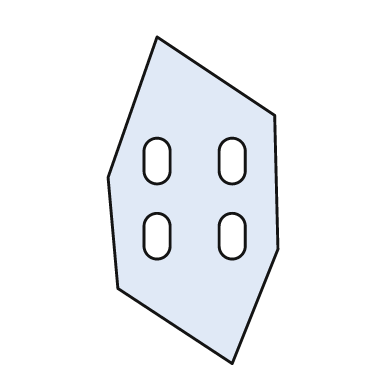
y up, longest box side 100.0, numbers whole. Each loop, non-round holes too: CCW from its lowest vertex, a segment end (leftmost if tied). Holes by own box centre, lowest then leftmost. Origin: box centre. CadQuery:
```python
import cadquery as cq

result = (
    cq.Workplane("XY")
    .moveTo(12.0, -50.0)
    .lineTo(26.0, -15.0)
    .lineTo(25.0, 26.0)
    .lineTo(-11.0, 50.0)
    .lineTo(-26.0, 7.0)
    .lineTo(-23.0, -27.0)
    .close()
    .moveTo(-15.0, -14.0)
    .threePointArc((-11.0, -18.0), (-7.0, -14.0))
    .lineTo(-7.0, -8.0)
    .threePointArc((-11.0, -4.0), (-15.0, -8.0))
    .close()
    .moveTo(8.0, -14.0)
    .threePointArc((12.0, -18.0), (16.0, -14.0))
    .lineTo(16.0, -8.0)
    .threePointArc((12.0, -4.0), (8.0, -8.0))
    .close()
    .moveTo(-15.0, 9.0)
    .threePointArc((-11.0, 5.0), (-7.0, 9.0))
    .lineTo(-7.0, 15.0)
    .threePointArc((-11.0, 19.0), (-15.0, 15.0))
    .close()
    .moveTo(8.0, 9.0)
    .threePointArc((12.0, 5.0), (16.0, 9.0))
    .lineTo(16.0, 15.0)
    .threePointArc((12.0, 19.0), (8.0, 15.0))
    .close()
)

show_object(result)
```